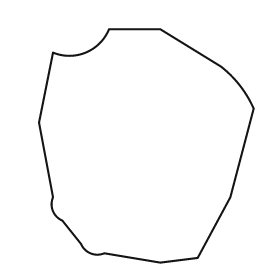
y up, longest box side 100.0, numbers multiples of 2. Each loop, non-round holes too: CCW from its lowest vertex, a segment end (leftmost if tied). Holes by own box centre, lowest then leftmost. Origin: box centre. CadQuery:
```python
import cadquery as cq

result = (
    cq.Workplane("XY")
    .moveTo(6.0, -50.0)
    .lineTo(22.0, -48.0)
    .lineTo(36.0, -22.0)
    .lineTo(46.0, 16.0)
    .threePointArc((40.0, 26.0), (32.0, 34.0))
    .lineTo(6.0, 50.0)
    .lineTo(-16.0, 50.0)
    .threePointArc((-26.0, 40.0), (-40.0, 40.0))
    .lineTo(-46.0, 10.0)
    .lineTo(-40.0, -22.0)
    .threePointArc((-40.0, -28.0), (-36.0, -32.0))
    .lineTo(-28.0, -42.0)
    .threePointArc((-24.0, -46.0), (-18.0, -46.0))
    .close()
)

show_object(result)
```